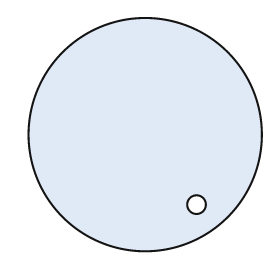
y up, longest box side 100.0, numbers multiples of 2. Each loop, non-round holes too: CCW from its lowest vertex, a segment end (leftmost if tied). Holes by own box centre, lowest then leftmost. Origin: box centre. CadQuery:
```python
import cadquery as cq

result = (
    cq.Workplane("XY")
    .moveTo(0.0, 0.0)
    .circle(50.0)
    .moveTo(22.0, -30.0)
    .circle(4.0)
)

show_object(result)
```